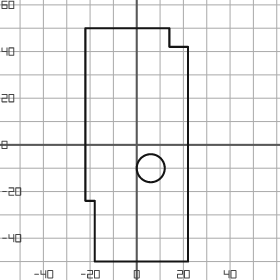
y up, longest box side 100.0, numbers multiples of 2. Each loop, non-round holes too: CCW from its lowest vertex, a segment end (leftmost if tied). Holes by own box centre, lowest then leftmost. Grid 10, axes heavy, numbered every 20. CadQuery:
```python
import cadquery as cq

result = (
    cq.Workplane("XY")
    .moveTo(-18.0, -50.0)
    .lineTo(22.0, -50.0)
    .lineTo(22.0, 42.0)
    .lineTo(14.0, 42.0)
    .lineTo(14.0, 50.0)
    .lineTo(-22.0, 50.0)
    .lineTo(-22.0, -24.0)
    .lineTo(-18.0, -24.0)
    .close()
    .moveTo(6.0, -10.0)
    .circle(6.0)
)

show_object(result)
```